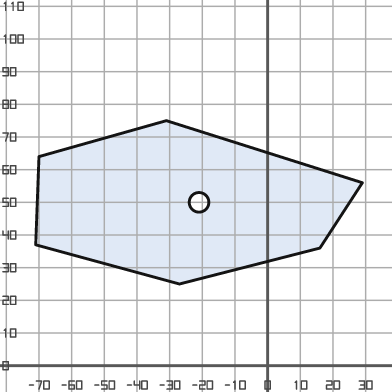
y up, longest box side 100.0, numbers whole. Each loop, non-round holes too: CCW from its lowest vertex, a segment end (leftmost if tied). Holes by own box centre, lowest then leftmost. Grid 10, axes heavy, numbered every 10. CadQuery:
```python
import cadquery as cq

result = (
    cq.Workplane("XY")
    .moveTo(-27.0, 25.0)
    .lineTo(16.0, 36.0)
    .lineTo(29.0, 56.0)
    .lineTo(-31.0, 75.0)
    .lineTo(-70.0, 64.0)
    .lineTo(-71.0, 37.0)
    .close()
    .moveTo(-21.0, 50.0)
    .circle(3.0)
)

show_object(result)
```